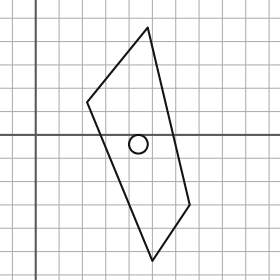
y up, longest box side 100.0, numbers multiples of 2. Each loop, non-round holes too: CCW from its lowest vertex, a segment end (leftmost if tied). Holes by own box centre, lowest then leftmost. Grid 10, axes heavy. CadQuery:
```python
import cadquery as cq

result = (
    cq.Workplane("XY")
    .moveTo(50.0, -54.0)
    .lineTo(66.0, -30.0)
    .lineTo(48.0, 46.0)
    .lineTo(22.0, 14.0)
    .close()
    .moveTo(44.0, -4.0)
    .circle(4.0)
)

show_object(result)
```